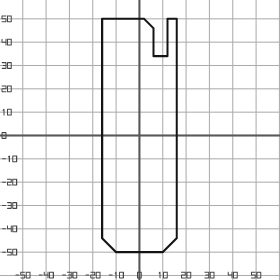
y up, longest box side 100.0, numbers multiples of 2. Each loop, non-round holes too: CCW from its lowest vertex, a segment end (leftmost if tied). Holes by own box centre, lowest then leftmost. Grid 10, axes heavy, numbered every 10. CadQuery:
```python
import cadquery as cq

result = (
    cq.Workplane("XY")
    .moveTo(-10.0, -50.0)
    .lineTo(10.0, -50.0)
    .lineTo(16.0, -44.0)
    .lineTo(16.0, 50.0)
    .lineTo(12.0, 50.0)
    .lineTo(12.0, 34.0)
    .lineTo(6.0, 34.0)
    .lineTo(6.0, 46.0)
    .lineTo(2.0, 50.0)
    .lineTo(-16.0, 50.0)
    .lineTo(-16.0, -44.0)
    .close()
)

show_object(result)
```